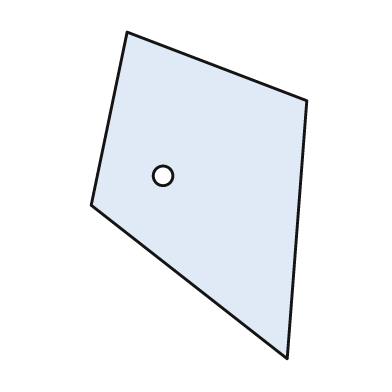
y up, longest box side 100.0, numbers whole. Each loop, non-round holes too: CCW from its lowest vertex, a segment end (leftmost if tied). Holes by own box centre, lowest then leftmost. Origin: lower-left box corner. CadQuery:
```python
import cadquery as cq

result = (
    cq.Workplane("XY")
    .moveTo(60.0, 0.0)
    .lineTo(66.0, 79.0)
    .lineTo(11.0, 100.0)
    .lineTo(0.0, 47.0)
    .close()
    .moveTo(22.0, 56.0)
    .circle(3.0)
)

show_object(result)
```